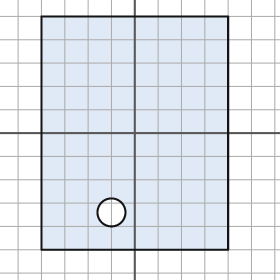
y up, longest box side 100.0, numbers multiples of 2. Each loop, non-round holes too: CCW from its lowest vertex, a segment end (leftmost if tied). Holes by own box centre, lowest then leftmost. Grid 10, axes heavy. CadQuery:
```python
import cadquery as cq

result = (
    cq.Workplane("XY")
    .moveTo(-40.0, -50.0)
    .lineTo(40.0, -50.0)
    .lineTo(40.0, 50.0)
    .lineTo(-40.0, 50.0)
    .close()
    .moveTo(-10.0, -34.0)
    .circle(6.0)
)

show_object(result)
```